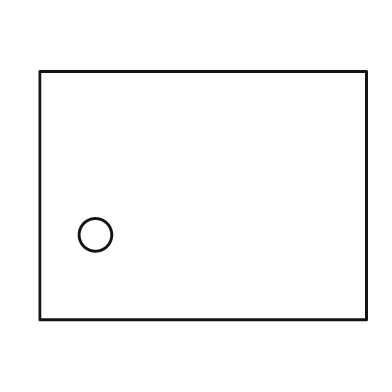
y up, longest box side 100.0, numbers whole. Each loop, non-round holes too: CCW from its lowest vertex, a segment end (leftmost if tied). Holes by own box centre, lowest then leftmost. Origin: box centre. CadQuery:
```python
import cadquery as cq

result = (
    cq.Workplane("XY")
    .moveTo(-50.0, -38.0)
    .lineTo(50.0, -38.0)
    .lineTo(50.0, 38.0)
    .lineTo(-50.0, 38.0)
    .close()
    .moveTo(-33.0, -12.0)
    .circle(5.0)
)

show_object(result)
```